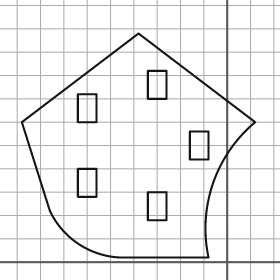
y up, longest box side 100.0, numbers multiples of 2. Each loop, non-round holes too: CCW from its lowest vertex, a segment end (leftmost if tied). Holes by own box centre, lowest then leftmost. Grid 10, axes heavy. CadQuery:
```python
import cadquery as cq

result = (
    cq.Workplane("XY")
    .moveTo(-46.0, 2.0)
    .lineTo(-8.0, 2.0)
    .threePointArc((-6.0, 34.0), (12.0, 60.0))
    .lineTo(-38.0, 98.0)
    .lineTo(-88.0, 60.0)
    .lineTo(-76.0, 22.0)
    .threePointArc((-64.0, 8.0), (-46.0, 2.0))
    .close()
    .moveTo(-34.0, 18.0)
    .lineTo(-26.0, 18.0)
    .lineTo(-26.0, 30.0)
    .lineTo(-34.0, 30.0)
    .close()
    .moveTo(-64.0, 28.0)
    .lineTo(-56.0, 28.0)
    .lineTo(-56.0, 40.0)
    .lineTo(-64.0, 40.0)
    .close()
    .moveTo(-16.0, 44.0)
    .lineTo(-8.0, 44.0)
    .lineTo(-8.0, 56.0)
    .lineTo(-16.0, 56.0)
    .close()
    .moveTo(-64.0, 60.0)
    .lineTo(-56.0, 60.0)
    .lineTo(-56.0, 72.0)
    .lineTo(-64.0, 72.0)
    .close()
    .moveTo(-34.0, 70.0)
    .lineTo(-26.0, 70.0)
    .lineTo(-26.0, 82.0)
    .lineTo(-34.0, 82.0)
    .close()
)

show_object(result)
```